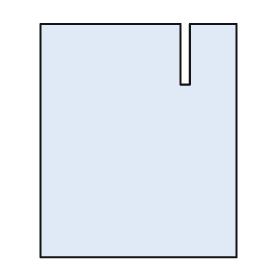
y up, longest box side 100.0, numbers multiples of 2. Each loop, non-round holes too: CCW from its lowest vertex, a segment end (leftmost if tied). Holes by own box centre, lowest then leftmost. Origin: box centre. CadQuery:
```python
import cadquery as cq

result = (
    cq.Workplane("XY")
    .moveTo(-42.0, -50.0)
    .lineTo(42.0, -50.0)
    .lineTo(42.0, 50.0)
    .lineTo(22.0, 50.0)
    .lineTo(22.0, 24.0)
    .lineTo(18.0, 24.0)
    .lineTo(18.0, 50.0)
    .lineTo(-42.0, 50.0)
    .close()
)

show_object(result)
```